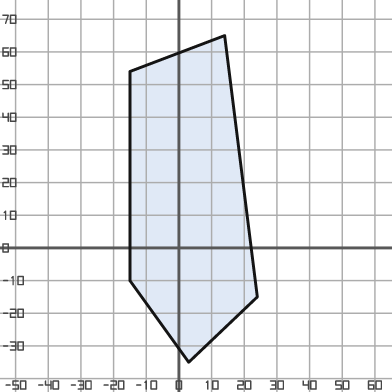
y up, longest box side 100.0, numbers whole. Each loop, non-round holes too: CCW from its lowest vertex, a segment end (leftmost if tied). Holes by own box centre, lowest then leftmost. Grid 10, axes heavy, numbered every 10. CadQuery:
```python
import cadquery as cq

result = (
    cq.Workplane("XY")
    .moveTo(3.0, -35.0)
    .lineTo(24.0, -15.0)
    .lineTo(14.0, 65.0)
    .lineTo(-15.0, 54.0)
    .lineTo(-15.0, -10.0)
    .close()
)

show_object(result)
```